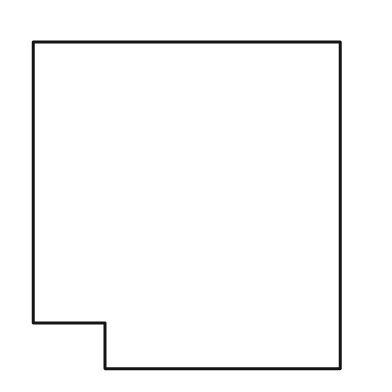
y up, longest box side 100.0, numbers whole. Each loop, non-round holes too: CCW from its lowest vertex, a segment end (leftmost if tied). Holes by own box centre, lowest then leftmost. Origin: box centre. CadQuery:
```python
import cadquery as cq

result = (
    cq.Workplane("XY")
    .moveTo(-25.0, -50.0)
    .lineTo(47.0, -50.0)
    .lineTo(47.0, 50.0)
    .lineTo(-47.0, 50.0)
    .lineTo(-47.0, -36.0)
    .lineTo(-25.0, -36.0)
    .close()
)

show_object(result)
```